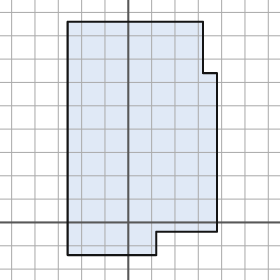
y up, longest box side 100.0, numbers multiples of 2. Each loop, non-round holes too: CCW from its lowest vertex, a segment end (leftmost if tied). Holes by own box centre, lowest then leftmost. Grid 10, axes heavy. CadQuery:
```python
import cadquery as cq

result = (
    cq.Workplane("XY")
    .moveTo(-26.0, -14.0)
    .lineTo(12.0, -14.0)
    .lineTo(12.0, -4.0)
    .lineTo(38.0, -4.0)
    .lineTo(38.0, 64.0)
    .lineTo(32.0, 64.0)
    .lineTo(32.0, 86.0)
    .lineTo(-26.0, 86.0)
    .close()
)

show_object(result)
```